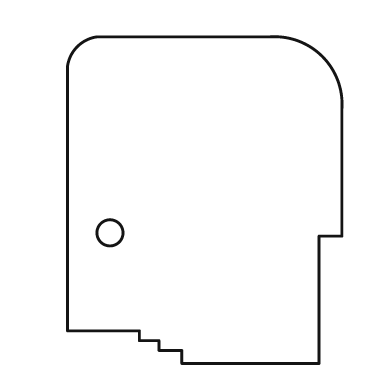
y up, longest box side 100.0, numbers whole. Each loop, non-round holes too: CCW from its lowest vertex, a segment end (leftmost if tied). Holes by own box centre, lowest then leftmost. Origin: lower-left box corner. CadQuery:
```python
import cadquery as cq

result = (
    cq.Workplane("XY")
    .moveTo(35.0, 0.0)
    .lineTo(77.0, 0.0)
    .lineTo(77.0, 39.0)
    .lineTo(84.0, 39.0)
    .lineTo(84.0, 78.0)
    .threePointArc((78.0, 94.0), (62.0, 100.0))
    .lineTo(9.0, 100.0)
    .threePointArc((3.0, 97.0), (0.0, 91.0))
    .lineTo(0.0, 10.0)
    .lineTo(22.0, 10.0)
    .lineTo(22.0, 7.0)
    .lineTo(28.0, 7.0)
    .lineTo(28.0, 4.0)
    .lineTo(35.0, 4.0)
    .close()
    .moveTo(13.0, 40.0)
    .circle(4.0)
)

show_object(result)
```